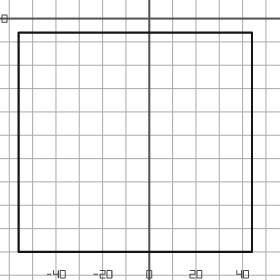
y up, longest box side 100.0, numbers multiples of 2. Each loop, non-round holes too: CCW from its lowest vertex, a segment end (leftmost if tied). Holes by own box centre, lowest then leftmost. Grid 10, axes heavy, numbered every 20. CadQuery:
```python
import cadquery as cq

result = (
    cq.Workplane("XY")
    .moveTo(-56.0, -100.0)
    .lineTo(44.0, -100.0)
    .lineTo(44.0, -6.0)
    .lineTo(-56.0, -6.0)
    .close()
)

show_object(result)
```